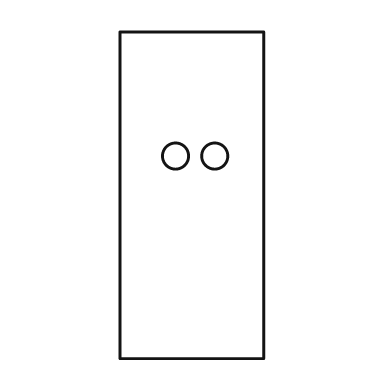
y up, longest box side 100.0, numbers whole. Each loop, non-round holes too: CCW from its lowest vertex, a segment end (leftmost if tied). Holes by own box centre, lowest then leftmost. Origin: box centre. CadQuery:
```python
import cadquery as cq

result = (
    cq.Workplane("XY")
    .moveTo(-22.0, -50.0)
    .lineTo(22.0, -50.0)
    .lineTo(22.0, 50.0)
    .lineTo(-22.0, 50.0)
    .close()
    .moveTo(-5.0, 12.0)
    .circle(4.0)
    .moveTo(7.0, 12.0)
    .circle(4.0)
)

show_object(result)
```